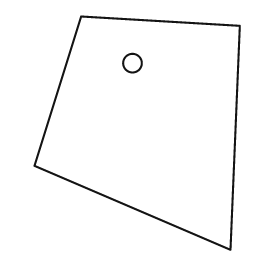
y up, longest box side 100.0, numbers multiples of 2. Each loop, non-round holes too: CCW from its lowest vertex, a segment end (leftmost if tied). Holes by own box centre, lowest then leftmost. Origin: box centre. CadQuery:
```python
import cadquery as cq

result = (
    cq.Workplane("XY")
    .moveTo(40.0, -50.0)
    .lineTo(44.0, 46.0)
    .lineTo(-24.0, 50.0)
    .lineTo(-44.0, -14.0)
    .close()
    .moveTo(-2.0, 30.0)
    .circle(4.0)
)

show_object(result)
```